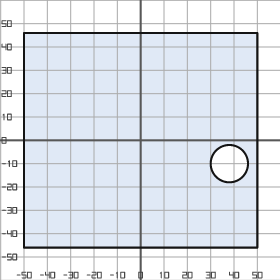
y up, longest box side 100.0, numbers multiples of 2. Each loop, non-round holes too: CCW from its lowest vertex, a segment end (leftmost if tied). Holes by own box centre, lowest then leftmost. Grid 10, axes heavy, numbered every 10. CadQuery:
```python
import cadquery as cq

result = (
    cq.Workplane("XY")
    .moveTo(-50.0, -46.0)
    .lineTo(50.0, -46.0)
    .lineTo(50.0, 46.0)
    .lineTo(-50.0, 46.0)
    .close()
    .moveTo(38.0, -10.0)
    .circle(8.0)
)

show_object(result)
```